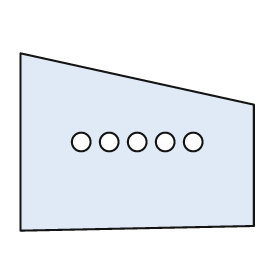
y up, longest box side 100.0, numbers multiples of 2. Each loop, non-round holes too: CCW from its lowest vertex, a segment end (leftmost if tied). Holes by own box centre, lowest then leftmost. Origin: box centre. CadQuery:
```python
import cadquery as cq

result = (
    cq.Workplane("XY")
    .moveTo(-50.0, -38.0)
    .lineTo(50.0, -36.0)
    .lineTo(50.0, 16.0)
    .lineTo(-50.0, 38.0)
    .close()
    .moveTo(-24.0, 0.0)
    .circle(4.0)
    .moveTo(-12.0, 0.0)
    .circle(4.0)
    .moveTo(0.0, 0.0)
    .circle(4.0)
    .moveTo(12.0, 0.0)
    .circle(4.0)
    .moveTo(24.0, 0.0)
    .circle(4.0)
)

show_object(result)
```